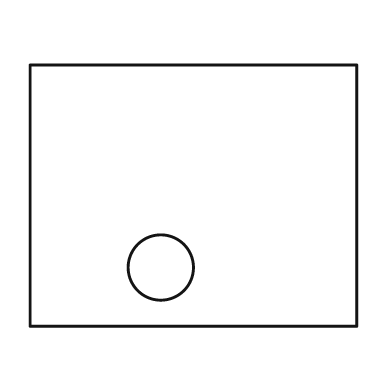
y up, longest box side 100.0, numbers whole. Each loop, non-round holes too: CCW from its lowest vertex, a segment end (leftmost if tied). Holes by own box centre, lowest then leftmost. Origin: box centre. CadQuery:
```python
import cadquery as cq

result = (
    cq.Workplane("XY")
    .moveTo(-50.0, -40.0)
    .lineTo(50.0, -40.0)
    .lineTo(50.0, 40.0)
    .lineTo(-50.0, 40.0)
    .close()
    .moveTo(-10.0, -22.0)
    .circle(10.0)
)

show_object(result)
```